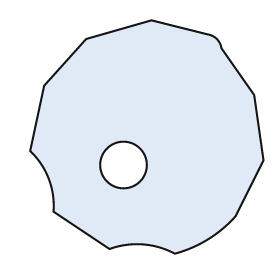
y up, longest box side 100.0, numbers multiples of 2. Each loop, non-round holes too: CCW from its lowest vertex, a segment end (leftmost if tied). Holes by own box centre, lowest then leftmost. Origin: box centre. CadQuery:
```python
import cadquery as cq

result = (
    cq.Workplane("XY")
    .moveTo(12.0, -50.0)
    .threePointArc((26.0, -44.0), (38.0, -34.0))
    .lineTo(50.0, -10.0)
    .lineTo(46.0, 18.0)
    .lineTo(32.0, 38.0)
    .threePointArc((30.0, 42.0), (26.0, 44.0))
    .lineTo(2.0, 50.0)
    .lineTo(-26.0, 42.0)
    .lineTo(-44.0, 22.0)
    .lineTo(-50.0, -6.0)
    .threePointArc((-42.0, -18.0), (-40.0, -32.0))
    .lineTo(-16.0, -48.0)
    .threePointArc((-2.0, -46.0), (12.0, -50.0))
    .close()
    .moveTo(-10.0, -12.0)
    .circle(10.0)
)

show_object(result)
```